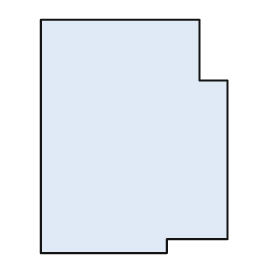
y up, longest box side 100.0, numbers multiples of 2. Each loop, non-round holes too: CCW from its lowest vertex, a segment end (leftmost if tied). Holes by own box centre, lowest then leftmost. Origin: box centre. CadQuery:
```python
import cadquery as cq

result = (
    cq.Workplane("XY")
    .moveTo(-40.0, -50.0)
    .lineTo(14.0, -50.0)
    .lineTo(14.0, -44.0)
    .lineTo(40.0, -44.0)
    .lineTo(40.0, 24.0)
    .lineTo(28.0, 24.0)
    .lineTo(28.0, 50.0)
    .lineTo(-40.0, 50.0)
    .close()
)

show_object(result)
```